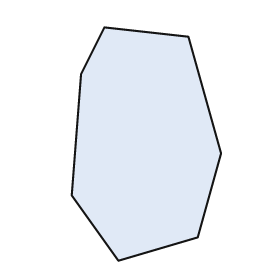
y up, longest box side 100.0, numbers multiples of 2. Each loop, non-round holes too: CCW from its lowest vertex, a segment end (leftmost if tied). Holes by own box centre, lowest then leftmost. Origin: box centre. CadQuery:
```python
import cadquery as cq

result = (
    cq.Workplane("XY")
    .moveTo(-12.0, -50.0)
    .lineTo(22.0, -40.0)
    .lineTo(32.0, -4.0)
    .lineTo(18.0, 46.0)
    .lineTo(-18.0, 50.0)
    .lineTo(-28.0, 30.0)
    .lineTo(-32.0, -22.0)
    .close()
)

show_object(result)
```